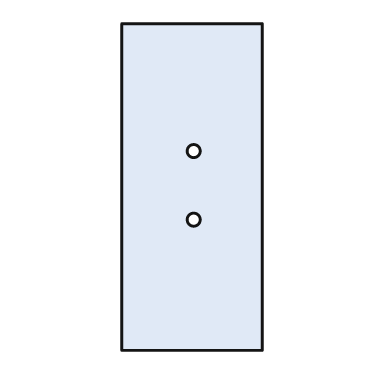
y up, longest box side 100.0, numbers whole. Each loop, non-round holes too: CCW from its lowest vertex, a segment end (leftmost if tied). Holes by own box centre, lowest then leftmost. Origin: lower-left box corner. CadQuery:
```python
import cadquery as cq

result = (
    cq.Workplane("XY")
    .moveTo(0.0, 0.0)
    .lineTo(43.0, 0.0)
    .lineTo(43.0, 100.0)
    .lineTo(0.0, 100.0)
    .close()
    .moveTo(22.0, 40.0)
    .circle(2.0)
    .moveTo(22.0, 61.0)
    .circle(2.0)
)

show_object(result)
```